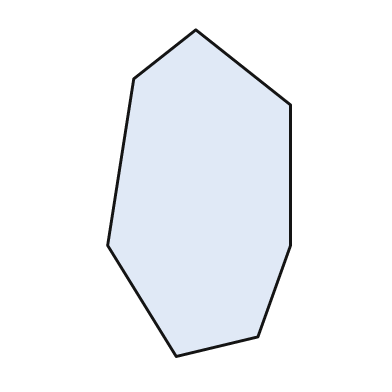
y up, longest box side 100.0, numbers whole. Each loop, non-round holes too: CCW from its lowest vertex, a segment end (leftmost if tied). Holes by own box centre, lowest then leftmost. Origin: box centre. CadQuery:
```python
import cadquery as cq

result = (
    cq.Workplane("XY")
    .moveTo(-7.0, -50.0)
    .lineTo(18.0, -44.0)
    .lineTo(28.0, -16.0)
    .lineTo(28.0, 27.0)
    .lineTo(-1.0, 50.0)
    .lineTo(-20.0, 35.0)
    .lineTo(-28.0, -16.0)
    .close()
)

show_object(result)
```